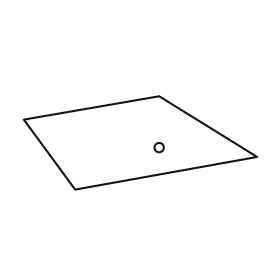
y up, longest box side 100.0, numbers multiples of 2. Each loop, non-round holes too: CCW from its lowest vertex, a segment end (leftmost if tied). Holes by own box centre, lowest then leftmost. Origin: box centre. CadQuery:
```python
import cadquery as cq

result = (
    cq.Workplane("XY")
    .moveTo(-28.0, -20.0)
    .lineTo(50.0, -6.0)
    .lineTo(8.0, 20.0)
    .lineTo(-50.0, 10.0)
    .close()
    .moveTo(8.0, -2.0)
    .circle(2.0)
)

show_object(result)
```